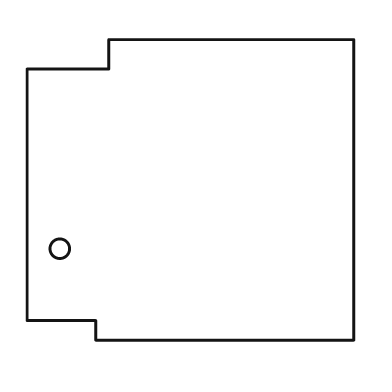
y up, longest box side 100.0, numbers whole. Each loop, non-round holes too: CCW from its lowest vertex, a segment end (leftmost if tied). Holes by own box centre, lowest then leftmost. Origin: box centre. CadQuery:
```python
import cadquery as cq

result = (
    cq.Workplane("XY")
    .moveTo(-29.0, -46.0)
    .lineTo(50.0, -46.0)
    .lineTo(50.0, 46.0)
    .lineTo(-25.0, 46.0)
    .lineTo(-25.0, 37.0)
    .lineTo(-50.0, 37.0)
    .lineTo(-50.0, -40.0)
    .lineTo(-29.0, -40.0)
    .close()
    .moveTo(-40.0, -18.0)
    .circle(3.0)
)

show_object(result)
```